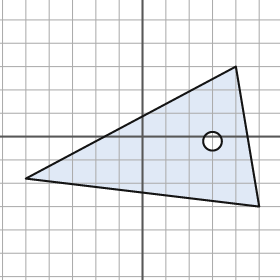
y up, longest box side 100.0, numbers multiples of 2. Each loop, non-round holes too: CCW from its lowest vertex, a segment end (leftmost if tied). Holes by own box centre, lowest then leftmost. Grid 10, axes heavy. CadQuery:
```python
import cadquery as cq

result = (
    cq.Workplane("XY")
    .moveTo(50.0, -30.0)
    .lineTo(40.0, 30.0)
    .lineTo(-50.0, -18.0)
    .close()
    .moveTo(30.0, -2.0)
    .circle(4.0)
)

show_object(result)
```